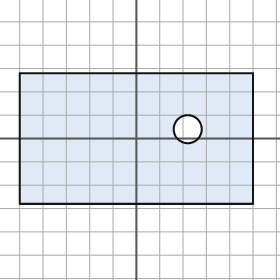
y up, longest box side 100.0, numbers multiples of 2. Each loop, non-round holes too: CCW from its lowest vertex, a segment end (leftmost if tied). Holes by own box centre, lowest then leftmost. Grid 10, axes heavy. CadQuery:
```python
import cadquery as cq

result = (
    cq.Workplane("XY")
    .moveTo(-50.0, -28.0)
    .lineTo(50.0, -28.0)
    .lineTo(50.0, 28.0)
    .lineTo(-50.0, 28.0)
    .close()
    .moveTo(22.0, 4.0)
    .circle(6.0)
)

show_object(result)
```